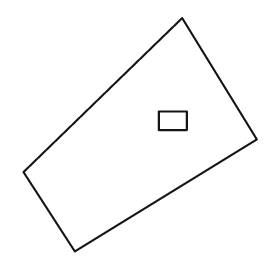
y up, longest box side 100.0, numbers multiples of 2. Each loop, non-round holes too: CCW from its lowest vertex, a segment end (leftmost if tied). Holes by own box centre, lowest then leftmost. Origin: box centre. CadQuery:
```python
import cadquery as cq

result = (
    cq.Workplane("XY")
    .moveTo(-28.0, -50.0)
    .lineTo(50.0, -2.0)
    .lineTo(18.0, 50.0)
    .lineTo(-50.0, -16.0)
    .close()
    .moveTo(8.0, 2.0)
    .lineTo(20.0, 2.0)
    .lineTo(20.0, 10.0)
    .lineTo(8.0, 10.0)
    .close()
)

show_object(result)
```